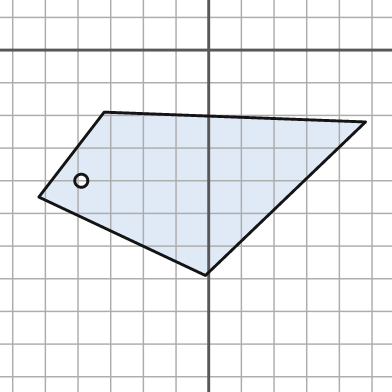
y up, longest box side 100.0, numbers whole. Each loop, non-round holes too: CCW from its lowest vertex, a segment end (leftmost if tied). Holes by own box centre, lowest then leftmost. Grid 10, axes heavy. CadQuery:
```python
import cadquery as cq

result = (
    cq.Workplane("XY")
    .moveTo(-1.0, -69.0)
    .lineTo(48.0, -22.0)
    .lineTo(-32.0, -19.0)
    .lineTo(-52.0, -45.0)
    .close()
    .moveTo(-39.0, -40.0)
    .circle(2.0)
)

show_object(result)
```